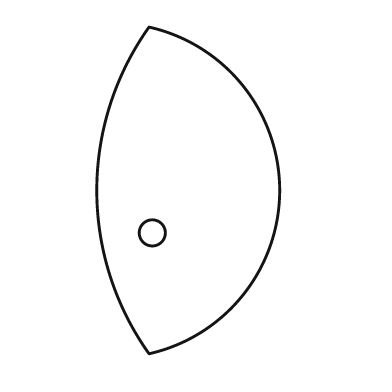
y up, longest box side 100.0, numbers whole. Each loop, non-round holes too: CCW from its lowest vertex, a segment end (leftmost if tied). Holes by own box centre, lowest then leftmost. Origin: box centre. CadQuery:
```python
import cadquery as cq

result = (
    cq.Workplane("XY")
    .moveTo(-12.0, -50.0)
    .threePointArc((28.0, 0.0), (-12.0, 50.0))
    .threePointArc((-28.0, 0.0), (-12.0, -50.0))
    .close()
    .moveTo(-11.0, -13.0)
    .circle(4.0)
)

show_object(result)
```